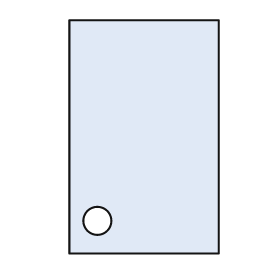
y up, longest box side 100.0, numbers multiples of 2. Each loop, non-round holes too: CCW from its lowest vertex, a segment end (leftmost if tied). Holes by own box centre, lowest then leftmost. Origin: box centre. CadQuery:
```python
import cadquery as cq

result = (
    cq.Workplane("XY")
    .moveTo(-32.0, -50.0)
    .lineTo(32.0, -50.0)
    .lineTo(32.0, 50.0)
    .lineTo(-32.0, 50.0)
    .close()
    .moveTo(-20.0, -36.0)
    .circle(6.0)
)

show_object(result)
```